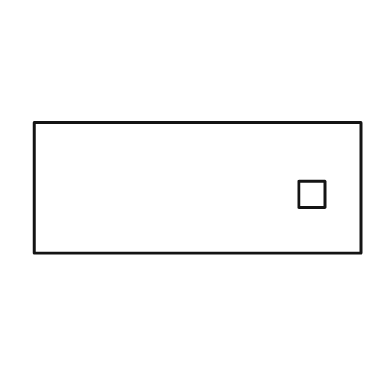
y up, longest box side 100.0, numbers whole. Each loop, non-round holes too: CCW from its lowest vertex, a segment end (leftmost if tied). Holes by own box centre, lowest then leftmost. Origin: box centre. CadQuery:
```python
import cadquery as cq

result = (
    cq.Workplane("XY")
    .moveTo(-50.0, -20.0)
    .lineTo(50.0, -20.0)
    .lineTo(50.0, 20.0)
    .lineTo(-50.0, 20.0)
    .close()
    .moveTo(31.0, -6.0)
    .lineTo(39.0, -6.0)
    .lineTo(39.0, 2.0)
    .lineTo(31.0, 2.0)
    .close()
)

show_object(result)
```